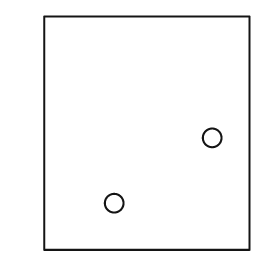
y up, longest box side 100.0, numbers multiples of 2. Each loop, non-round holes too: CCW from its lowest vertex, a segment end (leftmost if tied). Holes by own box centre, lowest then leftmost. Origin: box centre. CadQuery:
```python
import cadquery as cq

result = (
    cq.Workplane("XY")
    .moveTo(-44.0, -50.0)
    .lineTo(44.0, -50.0)
    .lineTo(44.0, 50.0)
    .lineTo(-44.0, 50.0)
    .close()
    .moveTo(-14.0, -30.0)
    .circle(4.0)
    .moveTo(28.0, -2.0)
    .circle(4.0)
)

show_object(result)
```